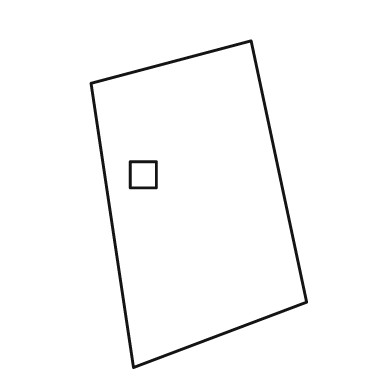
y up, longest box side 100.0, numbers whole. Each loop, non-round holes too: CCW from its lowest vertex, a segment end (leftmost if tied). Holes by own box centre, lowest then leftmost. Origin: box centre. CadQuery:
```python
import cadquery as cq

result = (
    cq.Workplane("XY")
    .moveTo(-20.0, -50.0)
    .lineTo(33.0, -30.0)
    .lineTo(16.0, 50.0)
    .lineTo(-33.0, 37.0)
    .close()
    .moveTo(-21.0, 5.0)
    .lineTo(-13.0, 5.0)
    .lineTo(-13.0, 13.0)
    .lineTo(-21.0, 13.0)
    .close()
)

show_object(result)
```